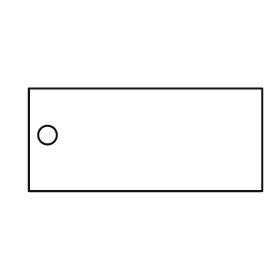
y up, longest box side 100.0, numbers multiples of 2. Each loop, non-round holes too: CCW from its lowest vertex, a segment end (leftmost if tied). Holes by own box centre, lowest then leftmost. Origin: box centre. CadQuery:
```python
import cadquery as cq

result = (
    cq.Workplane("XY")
    .moveTo(-50.0, -22.0)
    .lineTo(50.0, -22.0)
    .lineTo(50.0, 22.0)
    .lineTo(-50.0, 22.0)
    .close()
    .moveTo(-42.0, 2.0)
    .circle(4.0)
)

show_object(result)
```